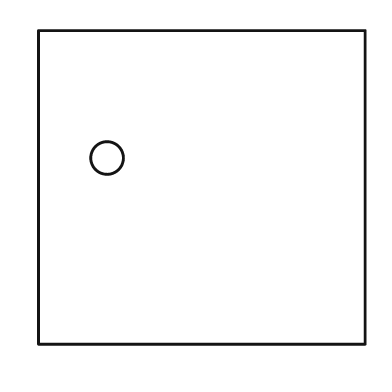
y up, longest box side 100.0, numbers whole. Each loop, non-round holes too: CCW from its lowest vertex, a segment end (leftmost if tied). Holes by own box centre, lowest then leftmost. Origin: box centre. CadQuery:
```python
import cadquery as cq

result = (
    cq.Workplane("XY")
    .moveTo(-50.0, -48.0)
    .lineTo(50.0, -48.0)
    .lineTo(50.0, 48.0)
    .lineTo(-50.0, 48.0)
    .close()
    .moveTo(-29.0, 9.0)
    .circle(5.0)
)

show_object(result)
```